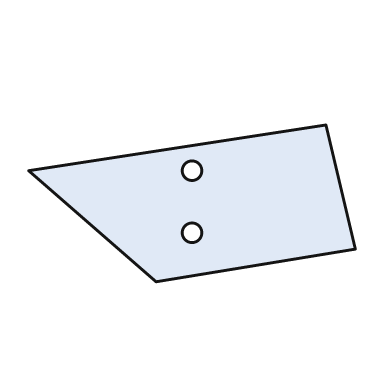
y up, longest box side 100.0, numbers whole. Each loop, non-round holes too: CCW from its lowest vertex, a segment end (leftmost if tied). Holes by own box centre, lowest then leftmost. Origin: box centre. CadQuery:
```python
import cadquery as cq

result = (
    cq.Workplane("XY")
    .moveTo(-11.0, -24.0)
    .lineTo(50.0, -14.0)
    .lineTo(41.0, 24.0)
    .lineTo(-50.0, 10.0)
    .close()
    .moveTo(0.0, -9.0)
    .circle(3.0)
    .moveTo(0.0, 10.0)
    .circle(3.0)
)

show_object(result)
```